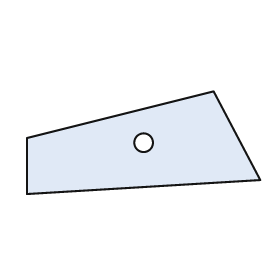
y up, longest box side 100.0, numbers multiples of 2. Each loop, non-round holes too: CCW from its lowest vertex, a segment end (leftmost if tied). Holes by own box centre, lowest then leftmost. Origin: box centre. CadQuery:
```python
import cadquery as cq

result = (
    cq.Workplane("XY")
    .moveTo(-50.0, -22.0)
    .lineTo(50.0, -16.0)
    .lineTo(30.0, 22.0)
    .lineTo(-50.0, 2.0)
    .close()
    .moveTo(0.0, 0.0)
    .circle(4.0)
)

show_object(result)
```